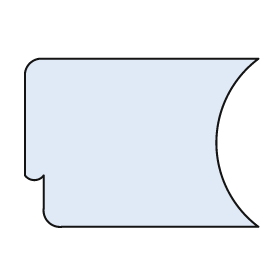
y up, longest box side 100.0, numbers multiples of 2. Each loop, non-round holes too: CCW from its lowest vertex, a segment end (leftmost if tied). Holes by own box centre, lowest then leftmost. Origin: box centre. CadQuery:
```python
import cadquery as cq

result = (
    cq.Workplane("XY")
    .moveTo(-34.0, -36.0)
    .lineTo(50.0, -36.0)
    .threePointArc((32.0, 0.0), (50.0, 36.0))
    .lineTo(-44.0, 36.0)
    .threePointArc((-48.0, 34.0), (-50.0, 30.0))
    .lineTo(-50.0, -14.0)
    .threePointArc((-46.0, -16.0), (-42.0, -14.0))
    .lineTo(-42.0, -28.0)
    .threePointArc((-40.0, -34.0), (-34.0, -36.0))
    .close()
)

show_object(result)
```